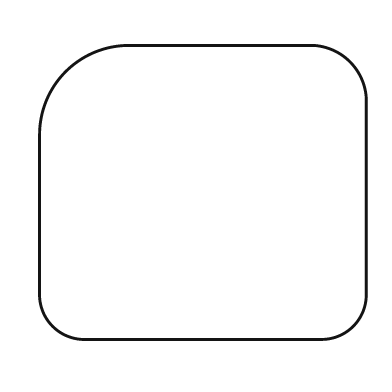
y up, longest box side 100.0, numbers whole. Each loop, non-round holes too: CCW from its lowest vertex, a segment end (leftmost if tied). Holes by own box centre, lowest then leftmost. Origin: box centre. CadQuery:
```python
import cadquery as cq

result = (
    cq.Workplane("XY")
    .moveTo(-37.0, -45.0)
    .lineTo(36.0, -45.0)
    .threePointArc((46.0, -41.0), (50.0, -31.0))
    .lineTo(50.0, 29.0)
    .threePointArc((45.0, 40.0), (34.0, 45.0))
    .lineTo(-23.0, 45.0)
    .threePointArc((-42.0, 37.0), (-50.0, 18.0))
    .lineTo(-50.0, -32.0)
    .threePointArc((-46.0, -41.0), (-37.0, -45.0))
    .close()
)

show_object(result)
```